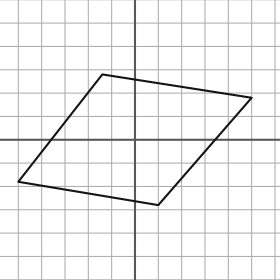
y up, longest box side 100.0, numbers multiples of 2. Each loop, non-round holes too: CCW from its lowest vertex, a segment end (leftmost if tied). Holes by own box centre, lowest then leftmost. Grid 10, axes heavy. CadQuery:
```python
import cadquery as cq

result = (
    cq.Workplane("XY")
    .moveTo(10.0, -28.0)
    .lineTo(50.0, 18.0)
    .lineTo(-14.0, 28.0)
    .lineTo(-50.0, -18.0)
    .close()
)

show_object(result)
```